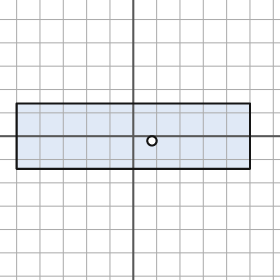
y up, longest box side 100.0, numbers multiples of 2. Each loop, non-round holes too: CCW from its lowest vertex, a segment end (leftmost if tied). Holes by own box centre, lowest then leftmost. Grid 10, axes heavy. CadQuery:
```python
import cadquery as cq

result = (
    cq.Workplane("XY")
    .moveTo(-50.0, -14.0)
    .lineTo(50.0, -14.0)
    .lineTo(50.0, 14.0)
    .lineTo(-50.0, 14.0)
    .close()
    .moveTo(8.0, -2.0)
    .circle(2.0)
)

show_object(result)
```